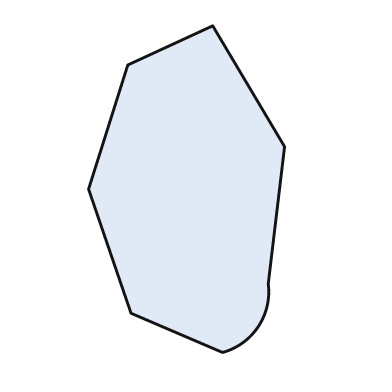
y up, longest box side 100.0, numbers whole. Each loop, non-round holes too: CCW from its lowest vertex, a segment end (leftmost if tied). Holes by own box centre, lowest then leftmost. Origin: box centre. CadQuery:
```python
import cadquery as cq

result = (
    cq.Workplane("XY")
    .moveTo(11.0, -50.0)
    .threePointArc((22.0, -42.0), (25.0, -29.0))
    .lineTo(30.0, 13.0)
    .lineTo(8.0, 50.0)
    .lineTo(-18.0, 38.0)
    .lineTo(-30.0, 0.0)
    .lineTo(-17.0, -38.0)
    .close()
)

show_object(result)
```